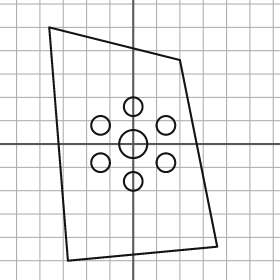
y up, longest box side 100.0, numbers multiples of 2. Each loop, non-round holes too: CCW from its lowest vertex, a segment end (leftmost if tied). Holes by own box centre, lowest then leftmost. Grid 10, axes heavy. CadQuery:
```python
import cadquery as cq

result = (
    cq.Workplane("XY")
    .moveTo(-28.0, -50.0)
    .lineTo(36.0, -44.0)
    .lineTo(20.0, 36.0)
    .lineTo(-36.0, 50.0)
    .close()
    .moveTo(0.0, -16.0)
    .circle(4.0)
    .moveTo(-14.0, -8.0)
    .circle(4.0)
    .moveTo(14.0, -8.0)
    .circle(4.0)
    .moveTo(0.0, 0.0)
    .circle(6.0)
    .moveTo(-14.0, 8.0)
    .circle(4.0)
    .moveTo(14.0, 8.0)
    .circle(4.0)
    .moveTo(0.0, 16.0)
    .circle(4.0)
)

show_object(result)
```